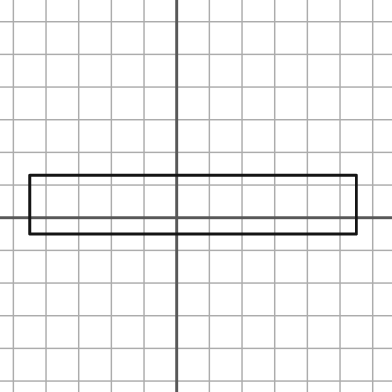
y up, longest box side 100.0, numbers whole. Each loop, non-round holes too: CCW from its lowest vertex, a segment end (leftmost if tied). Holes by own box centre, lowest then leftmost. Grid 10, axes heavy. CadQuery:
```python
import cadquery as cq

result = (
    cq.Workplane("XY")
    .moveTo(-45.0, -5.0)
    .lineTo(55.0, -5.0)
    .lineTo(55.0, 13.0)
    .lineTo(-45.0, 13.0)
    .close()
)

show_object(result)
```